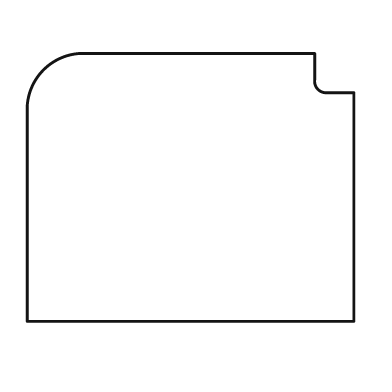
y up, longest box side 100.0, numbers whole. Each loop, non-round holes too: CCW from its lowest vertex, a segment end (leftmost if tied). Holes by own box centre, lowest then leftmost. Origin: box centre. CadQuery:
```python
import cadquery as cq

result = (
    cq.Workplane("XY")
    .moveTo(-50.0, -41.0)
    .lineTo(50.0, -41.0)
    .lineTo(50.0, 29.0)
    .lineTo(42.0, 29.0)
    .threePointArc((39.0, 30.0), (38.0, 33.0))
    .lineTo(38.0, 41.0)
    .lineTo(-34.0, 41.0)
    .threePointArc((-45.0, 36.0), (-50.0, 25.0))
    .close()
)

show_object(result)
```